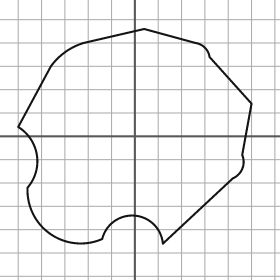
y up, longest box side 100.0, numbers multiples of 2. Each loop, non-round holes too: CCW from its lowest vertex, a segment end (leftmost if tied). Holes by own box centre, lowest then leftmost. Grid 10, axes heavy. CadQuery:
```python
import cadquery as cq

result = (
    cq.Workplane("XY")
    .moveTo(12.0, -46.0)
    .lineTo(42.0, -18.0)
    .threePointArc((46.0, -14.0), (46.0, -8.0))
    .lineTo(50.0, 14.0)
    .lineTo(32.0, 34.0)
    .threePointArc((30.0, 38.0), (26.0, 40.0))
    .lineTo(4.0, 46.0)
    .lineTo(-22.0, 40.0)
    .threePointArc((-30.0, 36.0), (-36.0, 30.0))
    .lineTo(-50.0, 4.0)
    .threePointArc((-42.0, -8.0), (-46.0, -22.0))
    .threePointArc((-36.0, -42.0), (-14.0, -44.0))
    .threePointArc((0.0, -34.0), (12.0, -46.0))
    .close()
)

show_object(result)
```